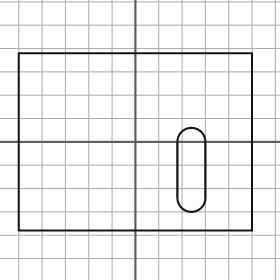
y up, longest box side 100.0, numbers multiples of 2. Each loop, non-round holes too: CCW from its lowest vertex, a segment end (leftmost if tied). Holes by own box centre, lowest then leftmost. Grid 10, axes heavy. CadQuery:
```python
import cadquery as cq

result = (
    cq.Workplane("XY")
    .moveTo(-50.0, -38.0)
    .lineTo(50.0, -38.0)
    .lineTo(50.0, 38.0)
    .lineTo(-50.0, 38.0)
    .close()
    .moveTo(18.0, -24.0)
    .threePointArc((24.0, -30.0), (30.0, -24.0))
    .lineTo(30.0, 0.0)
    .threePointArc((24.0, 6.0), (18.0, 0.0))
    .close()
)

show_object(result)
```